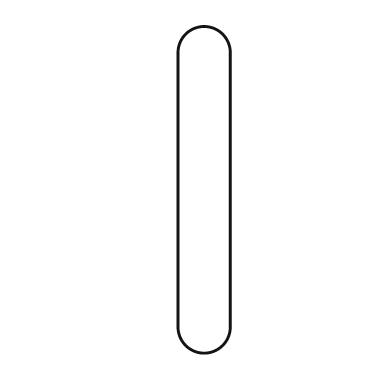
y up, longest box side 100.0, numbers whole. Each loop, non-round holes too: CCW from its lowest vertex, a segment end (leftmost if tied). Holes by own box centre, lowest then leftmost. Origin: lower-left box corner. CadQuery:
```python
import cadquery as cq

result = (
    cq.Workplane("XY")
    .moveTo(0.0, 8.0)
    .threePointArc((8.0, 0.0), (16.0, 8.0))
    .lineTo(16.0, 92.0)
    .threePointArc((8.0, 100.0), (0.0, 92.0))
    .close()
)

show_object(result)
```